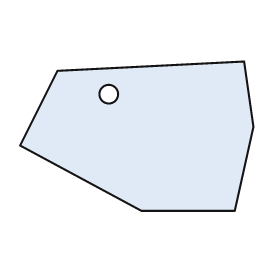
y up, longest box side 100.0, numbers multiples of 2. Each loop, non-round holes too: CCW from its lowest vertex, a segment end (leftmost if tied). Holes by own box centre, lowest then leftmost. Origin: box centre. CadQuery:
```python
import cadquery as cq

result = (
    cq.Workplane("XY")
    .moveTo(2.0, -32.0)
    .lineTo(42.0, -32.0)
    .lineTo(50.0, 4.0)
    .lineTo(46.0, 32.0)
    .lineTo(-34.0, 28.0)
    .lineTo(-50.0, -4.0)
    .close()
    .moveTo(-12.0, 18.0)
    .circle(4.0)
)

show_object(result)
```